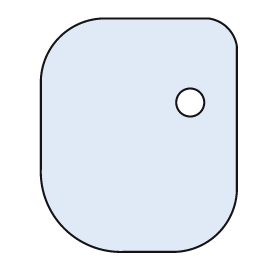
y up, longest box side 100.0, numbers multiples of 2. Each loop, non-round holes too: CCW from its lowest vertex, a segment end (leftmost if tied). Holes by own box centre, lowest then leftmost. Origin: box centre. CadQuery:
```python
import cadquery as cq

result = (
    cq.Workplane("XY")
    .moveTo(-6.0, -50.0)
    .lineTo(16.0, -50.0)
    .threePointArc((34.0, -42.0), (42.0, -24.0))
    .lineTo(42.0, 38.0)
    .threePointArc((38.0, 46.0), (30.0, 50.0))
    .lineTo(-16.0, 50.0)
    .threePointArc((-34.0, 42.0), (-42.0, 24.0))
    .lineTo(-42.0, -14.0)
    .threePointArc((-32.0, -40.0), (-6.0, -50.0))
    .close()
    .moveTo(22.0, 14.0)
    .circle(6.0)
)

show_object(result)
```